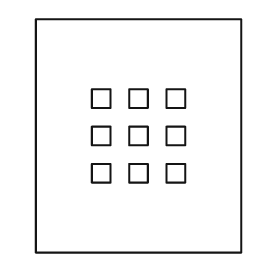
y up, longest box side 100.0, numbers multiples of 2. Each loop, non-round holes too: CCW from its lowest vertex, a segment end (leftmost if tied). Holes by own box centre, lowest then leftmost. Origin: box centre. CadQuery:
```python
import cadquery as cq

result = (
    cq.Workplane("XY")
    .moveTo(-44.0, -50.0)
    .lineTo(44.0, -50.0)
    .lineTo(44.0, 50.0)
    .lineTo(-44.0, 50.0)
    .close()
    .moveTo(-20.0, -20.0)
    .lineTo(-12.0, -20.0)
    .lineTo(-12.0, -12.0)
    .lineTo(-20.0, -12.0)
    .close()
    .moveTo(-4.0, -20.0)
    .lineTo(4.0, -20.0)
    .lineTo(4.0, -12.0)
    .lineTo(-4.0, -12.0)
    .close()
    .moveTo(12.0, -20.0)
    .lineTo(20.0, -20.0)
    .lineTo(20.0, -12.0)
    .lineTo(12.0, -12.0)
    .close()
    .moveTo(-20.0, -4.0)
    .lineTo(-12.0, -4.0)
    .lineTo(-12.0, 4.0)
    .lineTo(-20.0, 4.0)
    .close()
    .moveTo(-4.0, -4.0)
    .lineTo(4.0, -4.0)
    .lineTo(4.0, 4.0)
    .lineTo(-4.0, 4.0)
    .close()
    .moveTo(12.0, -4.0)
    .lineTo(20.0, -4.0)
    .lineTo(20.0, 4.0)
    .lineTo(12.0, 4.0)
    .close()
    .moveTo(-20.0, 12.0)
    .lineTo(-12.0, 12.0)
    .lineTo(-12.0, 20.0)
    .lineTo(-20.0, 20.0)
    .close()
    .moveTo(-4.0, 12.0)
    .lineTo(4.0, 12.0)
    .lineTo(4.0, 20.0)
    .lineTo(-4.0, 20.0)
    .close()
    .moveTo(12.0, 12.0)
    .lineTo(20.0, 12.0)
    .lineTo(20.0, 20.0)
    .lineTo(12.0, 20.0)
    .close()
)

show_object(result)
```